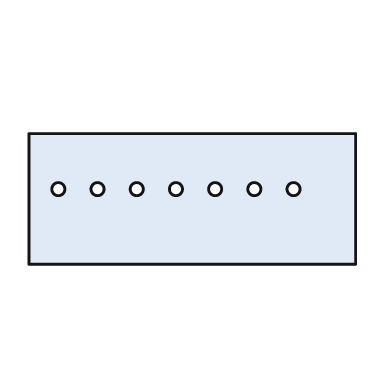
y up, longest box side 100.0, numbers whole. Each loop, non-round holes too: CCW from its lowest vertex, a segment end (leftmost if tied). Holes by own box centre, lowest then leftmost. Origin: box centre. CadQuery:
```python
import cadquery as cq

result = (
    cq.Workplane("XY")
    .moveTo(-50.0, -20.0)
    .lineTo(50.0, -20.0)
    .lineTo(50.0, 20.0)
    .lineTo(-50.0, 20.0)
    .close()
    .moveTo(-41.0, 3.0)
    .circle(2.0)
    .moveTo(-29.0, 3.0)
    .circle(2.0)
    .moveTo(-17.0, 3.0)
    .circle(2.0)
    .moveTo(-5.0, 3.0)
    .circle(2.0)
    .moveTo(7.0, 3.0)
    .circle(2.0)
    .moveTo(19.0, 3.0)
    .circle(2.0)
    .moveTo(31.0, 3.0)
    .circle(2.0)
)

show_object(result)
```